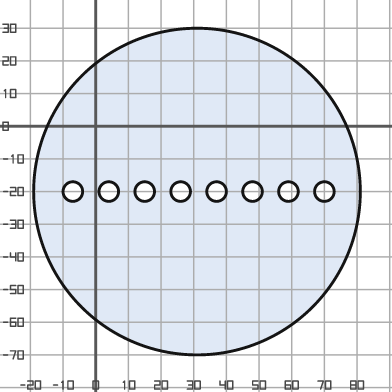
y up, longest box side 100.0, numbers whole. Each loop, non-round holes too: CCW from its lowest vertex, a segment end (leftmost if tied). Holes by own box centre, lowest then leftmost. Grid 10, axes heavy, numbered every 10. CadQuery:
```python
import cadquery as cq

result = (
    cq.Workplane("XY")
    .moveTo(31.0, -20.0)
    .circle(50.0)
    .moveTo(-7.0, -20.0)
    .circle(3.0)
    .moveTo(4.0, -20.0)
    .circle(3.0)
    .moveTo(15.0, -20.0)
    .circle(3.0)
    .moveTo(26.0, -20.0)
    .circle(3.0)
    .moveTo(37.0, -20.0)
    .circle(3.0)
    .moveTo(48.0, -20.0)
    .circle(3.0)
    .moveTo(59.0, -20.0)
    .circle(3.0)
    .moveTo(70.0, -20.0)
    .circle(3.0)
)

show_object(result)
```